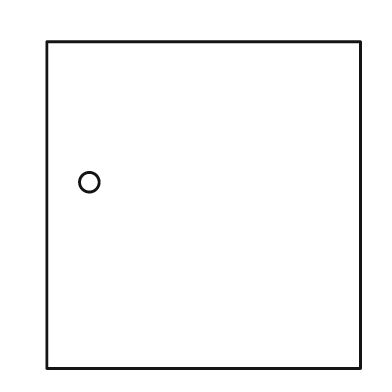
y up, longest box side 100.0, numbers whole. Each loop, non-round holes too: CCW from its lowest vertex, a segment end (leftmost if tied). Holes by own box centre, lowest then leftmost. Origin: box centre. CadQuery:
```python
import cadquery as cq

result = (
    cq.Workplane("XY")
    .moveTo(-48.0, -50.0)
    .lineTo(48.0, -50.0)
    .lineTo(48.0, 50.0)
    .lineTo(-48.0, 50.0)
    .close()
    .moveTo(-35.0, 7.0)
    .circle(3.0)
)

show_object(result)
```